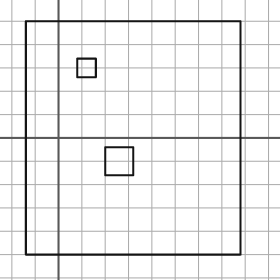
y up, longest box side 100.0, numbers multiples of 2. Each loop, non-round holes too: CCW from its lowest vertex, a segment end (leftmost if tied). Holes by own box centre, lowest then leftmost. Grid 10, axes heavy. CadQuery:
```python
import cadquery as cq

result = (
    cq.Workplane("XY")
    .moveTo(-14.0, -50.0)
    .lineTo(78.0, -50.0)
    .lineTo(78.0, 50.0)
    .lineTo(-14.0, 50.0)
    .close()
    .moveTo(20.0, -16.0)
    .lineTo(32.0, -16.0)
    .lineTo(32.0, -4.0)
    .lineTo(20.0, -4.0)
    .close()
    .moveTo(8.0, 26.0)
    .lineTo(16.0, 26.0)
    .lineTo(16.0, 34.0)
    .lineTo(8.0, 34.0)
    .close()
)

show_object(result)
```